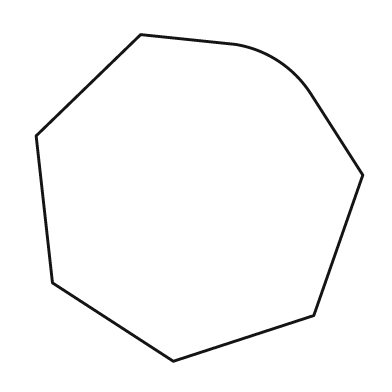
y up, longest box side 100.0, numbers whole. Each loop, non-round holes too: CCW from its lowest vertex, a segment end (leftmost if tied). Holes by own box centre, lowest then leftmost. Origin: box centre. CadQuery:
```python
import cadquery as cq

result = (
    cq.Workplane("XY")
    .moveTo(-8.0, -50.0)
    .lineTo(35.0, -36.0)
    .lineTo(50.0, 7.0)
    .lineTo(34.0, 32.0)
    .threePointArc((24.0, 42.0), (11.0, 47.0))
    .lineTo(-18.0, 50.0)
    .lineTo(-50.0, 19.0)
    .lineTo(-45.0, -26.0)
    .close()
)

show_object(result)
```